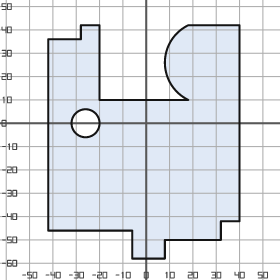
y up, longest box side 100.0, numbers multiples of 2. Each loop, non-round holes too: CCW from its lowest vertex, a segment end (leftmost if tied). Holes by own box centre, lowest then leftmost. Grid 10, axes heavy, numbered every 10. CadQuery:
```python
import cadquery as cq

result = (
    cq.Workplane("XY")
    .moveTo(-6.0, -58.0)
    .lineTo(8.0, -58.0)
    .lineTo(8.0, -50.0)
    .lineTo(32.0, -50.0)
    .lineTo(32.0, -42.0)
    .lineTo(40.0, -42.0)
    .lineTo(40.0, 42.0)
    .lineTo(18.0, 42.0)
    .threePointArc((8.0, 26.0), (18.0, 10.0))
    .lineTo(-20.0, 10.0)
    .lineTo(-20.0, 42.0)
    .lineTo(-28.0, 42.0)
    .lineTo(-28.0, 36.0)
    .lineTo(-42.0, 36.0)
    .lineTo(-42.0, -46.0)
    .lineTo(-6.0, -46.0)
    .close()
    .moveTo(-26.0, 0.0)
    .circle(6.0)
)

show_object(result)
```